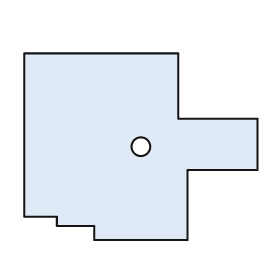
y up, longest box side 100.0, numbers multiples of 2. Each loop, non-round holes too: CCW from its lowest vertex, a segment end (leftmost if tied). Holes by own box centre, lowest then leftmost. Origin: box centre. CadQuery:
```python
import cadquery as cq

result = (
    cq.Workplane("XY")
    .moveTo(-20.0, -40.0)
    .lineTo(20.0, -40.0)
    .lineTo(20.0, -10.0)
    .lineTo(50.0, -10.0)
    .lineTo(50.0, 12.0)
    .lineTo(16.0, 12.0)
    .lineTo(16.0, 40.0)
    .lineTo(-50.0, 40.0)
    .lineTo(-50.0, -30.0)
    .lineTo(-36.0, -30.0)
    .lineTo(-36.0, -34.0)
    .lineTo(-20.0, -34.0)
    .close()
    .moveTo(0.0, 0.0)
    .circle(4.0)
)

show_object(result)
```